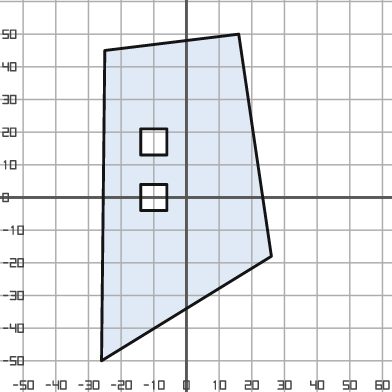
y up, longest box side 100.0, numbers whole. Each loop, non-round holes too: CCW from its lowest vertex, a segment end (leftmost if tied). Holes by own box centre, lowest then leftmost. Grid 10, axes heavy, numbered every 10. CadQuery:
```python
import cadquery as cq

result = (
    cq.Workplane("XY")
    .moveTo(-26.0, -50.0)
    .lineTo(26.0, -18.0)
    .lineTo(16.0, 50.0)
    .lineTo(-25.0, 45.0)
    .close()
    .moveTo(-14.0, -4.0)
    .lineTo(-6.0, -4.0)
    .lineTo(-6.0, 4.0)
    .lineTo(-14.0, 4.0)
    .close()
    .moveTo(-14.0, 13.0)
    .lineTo(-6.0, 13.0)
    .lineTo(-6.0, 21.0)
    .lineTo(-14.0, 21.0)
    .close()
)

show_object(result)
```